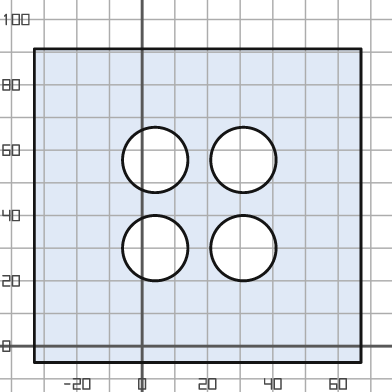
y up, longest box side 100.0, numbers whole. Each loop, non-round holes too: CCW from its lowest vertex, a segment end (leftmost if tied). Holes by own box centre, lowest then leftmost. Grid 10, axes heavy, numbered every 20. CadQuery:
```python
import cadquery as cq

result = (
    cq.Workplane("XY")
    .moveTo(-33.0, -5.0)
    .lineTo(67.0, -5.0)
    .lineTo(67.0, 91.0)
    .lineTo(-33.0, 91.0)
    .close()
    .moveTo(4.0, 30.0)
    .circle(10.0)
    .moveTo(31.0, 30.0)
    .circle(10.0)
    .moveTo(4.0, 57.0)
    .circle(10.0)
    .moveTo(31.0, 57.0)
    .circle(10.0)
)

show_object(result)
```